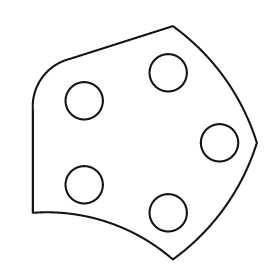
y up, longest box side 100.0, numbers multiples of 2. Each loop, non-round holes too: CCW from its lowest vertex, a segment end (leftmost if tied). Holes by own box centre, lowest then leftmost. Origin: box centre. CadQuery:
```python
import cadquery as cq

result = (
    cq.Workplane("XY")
    .moveTo(12.0, -50.0)
    .threePointArc((34.0, -28.0), (48.0, 0.0))
    .threePointArc((34.0, 28.0), (12.0, 50.0))
    .lineTo(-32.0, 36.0)
    .threePointArc((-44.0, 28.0), (-48.0, 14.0))
    .lineTo(-48.0, -30.0)
    .threePointArc((-16.0, -34.0), (12.0, -50.0))
    .close()
    .moveTo(10.0, -30.0)
    .circle(8.0)
    .moveTo(-26.0, -18.0)
    .circle(8.0)
    .moveTo(32.0, 0.0)
    .circle(8.0)
    .moveTo(-26.0, 18.0)
    .circle(8.0)
    .moveTo(10.0, 30.0)
    .circle(8.0)
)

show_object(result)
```